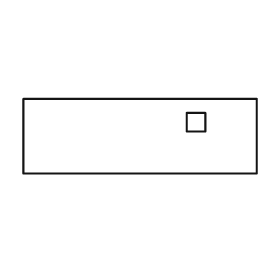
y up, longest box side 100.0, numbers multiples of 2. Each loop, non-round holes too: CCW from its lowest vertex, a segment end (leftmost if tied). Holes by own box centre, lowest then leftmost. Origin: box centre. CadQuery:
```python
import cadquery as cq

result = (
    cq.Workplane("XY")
    .moveTo(-50.0, -16.0)
    .lineTo(50.0, -16.0)
    .lineTo(50.0, 16.0)
    .lineTo(-50.0, 16.0)
    .close()
    .moveTo(20.0, 2.0)
    .lineTo(28.0, 2.0)
    .lineTo(28.0, 10.0)
    .lineTo(20.0, 10.0)
    .close()
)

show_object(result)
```